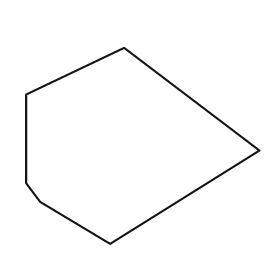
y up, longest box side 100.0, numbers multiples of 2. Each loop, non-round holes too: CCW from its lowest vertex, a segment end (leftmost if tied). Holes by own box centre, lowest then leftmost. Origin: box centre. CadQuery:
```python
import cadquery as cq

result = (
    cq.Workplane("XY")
    .moveTo(-14.0, -42.0)
    .lineTo(50.0, -2.0)
    .lineTo(-8.0, 42.0)
    .lineTo(-50.0, 22.0)
    .lineTo(-50.0, -16.0)
    .lineTo(-44.0, -24.0)
    .close()
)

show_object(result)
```